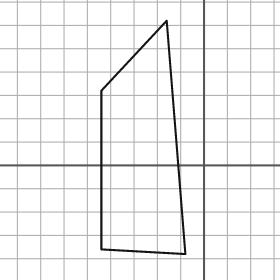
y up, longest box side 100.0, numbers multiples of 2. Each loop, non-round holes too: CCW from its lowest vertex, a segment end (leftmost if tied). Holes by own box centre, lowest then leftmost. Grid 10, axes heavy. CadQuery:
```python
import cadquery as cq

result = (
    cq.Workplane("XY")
    .moveTo(-8.0, -38.0)
    .lineTo(-16.0, 62.0)
    .lineTo(-44.0, 32.0)
    .lineTo(-44.0, -36.0)
    .close()
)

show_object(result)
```